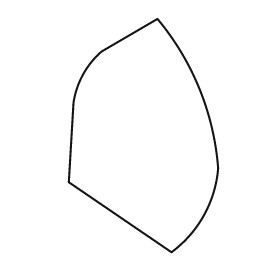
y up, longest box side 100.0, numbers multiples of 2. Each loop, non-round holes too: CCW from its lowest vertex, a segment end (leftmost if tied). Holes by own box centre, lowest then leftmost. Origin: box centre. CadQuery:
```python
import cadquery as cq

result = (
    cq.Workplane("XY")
    .moveTo(12.0, -50.0)
    .threePointArc((26.0, -34.0), (32.0, -14.0))
    .threePointArc((24.0, 20.0), (6.0, 50.0))
    .lineTo(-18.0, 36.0)
    .threePointArc((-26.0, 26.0), (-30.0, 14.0))
    .lineTo(-32.0, -20.0)
    .close()
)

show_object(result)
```